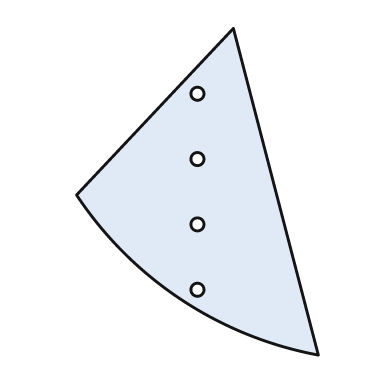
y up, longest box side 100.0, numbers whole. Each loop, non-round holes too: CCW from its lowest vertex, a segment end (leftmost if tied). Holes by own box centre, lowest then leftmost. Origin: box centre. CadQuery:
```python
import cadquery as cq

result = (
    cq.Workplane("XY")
    .moveTo(37.0, -50.0)
    .lineTo(11.0, 50.0)
    .lineTo(-37.0, -1.0)
    .threePointArc((-5.0, -33.0), (37.0, -50.0))
    .close()
    .moveTo(0.0, -30.0)
    .circle(2.0)
    .moveTo(0.0, -10.0)
    .circle(2.0)
    .moveTo(0.0, 10.0)
    .circle(2.0)
    .moveTo(0.0, 30.0)
    .circle(2.0)
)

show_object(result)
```